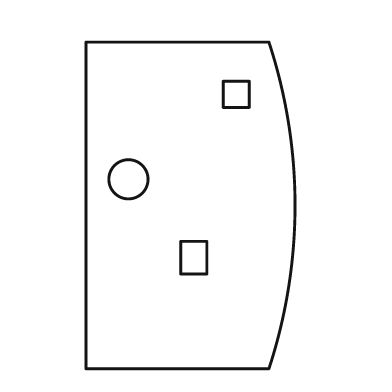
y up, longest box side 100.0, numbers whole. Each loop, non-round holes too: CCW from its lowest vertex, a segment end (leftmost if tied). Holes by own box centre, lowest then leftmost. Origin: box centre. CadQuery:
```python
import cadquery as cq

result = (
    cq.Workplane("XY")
    .moveTo(-32.0, -50.0)
    .lineTo(24.0, -50.0)
    .threePointArc((32.0, 0.0), (24.0, 50.0))
    .lineTo(-32.0, 50.0)
    .close()
    .moveTo(-3.0, -21.0)
    .lineTo(5.0, -21.0)
    .lineTo(5.0, -11.0)
    .lineTo(-3.0, -11.0)
    .close()
    .moveTo(-19.0, 8.0)
    .circle(6.0)
    .moveTo(10.0, 30.0)
    .lineTo(18.0, 30.0)
    .lineTo(18.0, 38.0)
    .lineTo(10.0, 38.0)
    .close()
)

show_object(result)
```